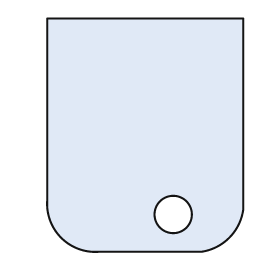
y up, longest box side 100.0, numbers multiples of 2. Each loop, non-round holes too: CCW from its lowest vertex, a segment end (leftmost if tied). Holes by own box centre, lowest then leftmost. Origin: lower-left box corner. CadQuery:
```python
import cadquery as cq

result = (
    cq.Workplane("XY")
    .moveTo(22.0, 0.0)
    .lineTo(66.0, 0.0)
    .threePointArc((78.0, 6.0), (84.0, 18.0))
    .lineTo(84.0, 100.0)
    .lineTo(0.0, 100.0)
    .lineTo(0.0, 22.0)
    .threePointArc((6.0, 6.0), (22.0, 0.0))
    .close()
    .moveTo(54.0, 16.0)
    .circle(8.0)
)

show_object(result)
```